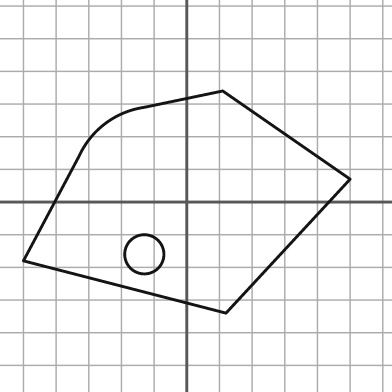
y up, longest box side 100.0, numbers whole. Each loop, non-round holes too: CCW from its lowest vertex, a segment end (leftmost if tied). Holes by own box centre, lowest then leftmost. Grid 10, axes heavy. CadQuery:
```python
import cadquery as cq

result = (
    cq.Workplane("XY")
    .moveTo(12.0, -34.0)
    .lineTo(50.0, 7.0)
    .lineTo(11.0, 34.0)
    .lineTo(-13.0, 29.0)
    .threePointArc((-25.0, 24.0), (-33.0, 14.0))
    .lineTo(-50.0, -18.0)
    .close()
    .moveTo(-13.0, -16.0)
    .circle(6.0)
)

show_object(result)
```